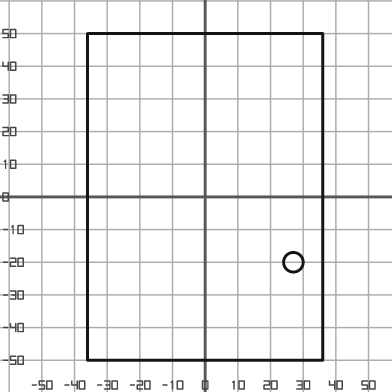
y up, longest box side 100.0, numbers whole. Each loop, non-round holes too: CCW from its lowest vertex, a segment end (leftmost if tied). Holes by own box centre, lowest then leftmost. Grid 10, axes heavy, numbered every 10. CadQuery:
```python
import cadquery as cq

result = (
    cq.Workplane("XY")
    .moveTo(-36.0, -50.0)
    .lineTo(36.0, -50.0)
    .lineTo(36.0, 50.0)
    .lineTo(-36.0, 50.0)
    .close()
    .moveTo(27.0, -20.0)
    .circle(3.0)
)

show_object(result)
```